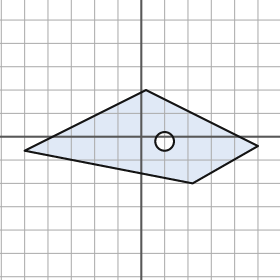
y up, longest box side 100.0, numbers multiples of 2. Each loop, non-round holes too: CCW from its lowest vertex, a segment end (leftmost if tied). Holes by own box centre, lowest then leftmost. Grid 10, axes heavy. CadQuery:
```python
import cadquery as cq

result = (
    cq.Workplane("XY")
    .moveTo(22.0, -20.0)
    .lineTo(50.0, -4.0)
    .lineTo(2.0, 20.0)
    .lineTo(-50.0, -6.0)
    .close()
    .moveTo(10.0, -2.0)
    .circle(4.0)
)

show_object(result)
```